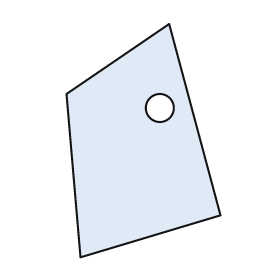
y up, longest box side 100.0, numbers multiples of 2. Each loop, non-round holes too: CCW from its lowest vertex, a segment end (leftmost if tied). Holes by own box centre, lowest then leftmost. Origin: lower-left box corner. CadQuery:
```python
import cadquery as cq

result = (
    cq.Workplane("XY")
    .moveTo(6.0, 0.0)
    .lineTo(66.0, 18.0)
    .lineTo(44.0, 100.0)
    .lineTo(0.0, 70.0)
    .close()
    .moveTo(40.0, 64.0)
    .circle(6.0)
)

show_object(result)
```